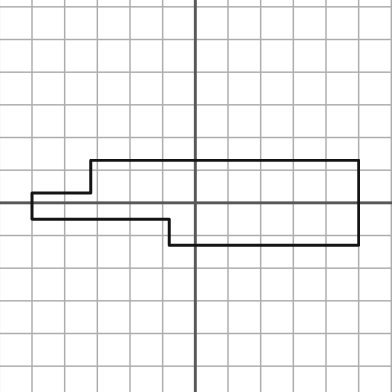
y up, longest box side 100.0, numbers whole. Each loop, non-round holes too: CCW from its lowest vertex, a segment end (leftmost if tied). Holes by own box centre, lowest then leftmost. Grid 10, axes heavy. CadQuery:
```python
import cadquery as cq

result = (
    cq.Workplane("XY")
    .moveTo(-8.0, -13.0)
    .lineTo(50.0, -13.0)
    .lineTo(50.0, 13.0)
    .lineTo(-32.0, 13.0)
    .lineTo(-32.0, 3.0)
    .lineTo(-50.0, 3.0)
    .lineTo(-50.0, -5.0)
    .lineTo(-8.0, -5.0)
    .close()
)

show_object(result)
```